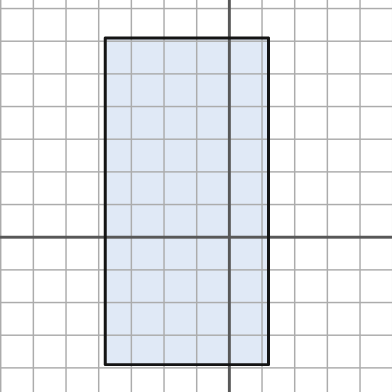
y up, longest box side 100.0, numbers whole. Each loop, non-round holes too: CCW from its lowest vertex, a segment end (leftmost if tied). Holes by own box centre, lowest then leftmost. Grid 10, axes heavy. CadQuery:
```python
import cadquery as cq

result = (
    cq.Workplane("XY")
    .moveTo(-38.0, -39.0)
    .lineTo(12.0, -39.0)
    .lineTo(12.0, 61.0)
    .lineTo(-38.0, 61.0)
    .close()
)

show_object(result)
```